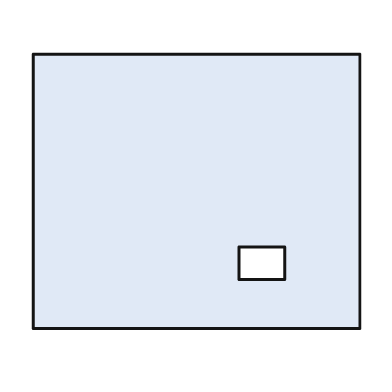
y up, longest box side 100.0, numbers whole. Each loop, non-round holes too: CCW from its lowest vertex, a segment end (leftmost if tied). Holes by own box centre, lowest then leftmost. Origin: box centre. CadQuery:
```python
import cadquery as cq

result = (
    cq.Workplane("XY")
    .moveTo(-50.0, -42.0)
    .lineTo(50.0, -42.0)
    .lineTo(50.0, 42.0)
    .lineTo(-50.0, 42.0)
    .close()
    .moveTo(13.0, -27.0)
    .lineTo(27.0, -27.0)
    .lineTo(27.0, -17.0)
    .lineTo(13.0, -17.0)
    .close()
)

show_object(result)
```